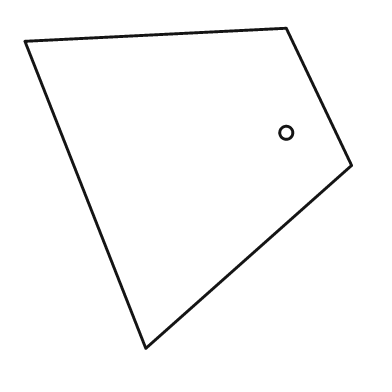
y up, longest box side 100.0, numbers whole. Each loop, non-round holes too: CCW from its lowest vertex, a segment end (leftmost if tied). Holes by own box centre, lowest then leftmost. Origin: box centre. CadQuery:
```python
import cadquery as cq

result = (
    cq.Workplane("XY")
    .moveTo(-13.0, -49.0)
    .lineTo(50.0, 7.0)
    .lineTo(30.0, 49.0)
    .lineTo(-50.0, 45.0)
    .close()
    .moveTo(30.0, 17.0)
    .circle(2.0)
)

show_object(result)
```